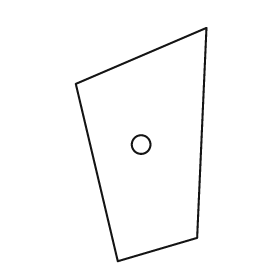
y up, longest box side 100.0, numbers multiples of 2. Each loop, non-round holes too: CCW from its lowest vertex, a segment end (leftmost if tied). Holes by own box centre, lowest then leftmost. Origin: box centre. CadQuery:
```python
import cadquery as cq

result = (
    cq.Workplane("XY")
    .moveTo(-10.0, -50.0)
    .lineTo(24.0, -40.0)
    .lineTo(28.0, 50.0)
    .lineTo(-28.0, 26.0)
    .close()
    .moveTo(0.0, 0.0)
    .circle(4.0)
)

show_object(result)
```